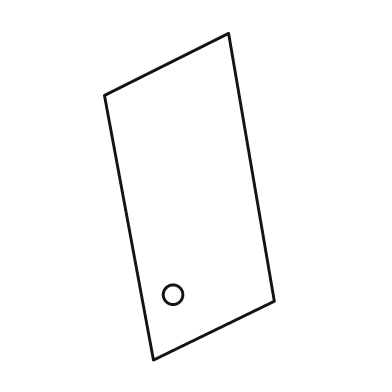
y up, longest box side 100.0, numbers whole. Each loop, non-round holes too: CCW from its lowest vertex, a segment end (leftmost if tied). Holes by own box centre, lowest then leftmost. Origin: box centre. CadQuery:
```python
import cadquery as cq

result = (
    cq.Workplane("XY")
    .moveTo(-11.0, -50.0)
    .lineTo(26.0, -32.0)
    .lineTo(12.0, 50.0)
    .lineTo(-26.0, 31.0)
    .close()
    .moveTo(-5.0, -30.0)
    .circle(3.0)
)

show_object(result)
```